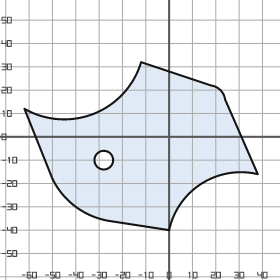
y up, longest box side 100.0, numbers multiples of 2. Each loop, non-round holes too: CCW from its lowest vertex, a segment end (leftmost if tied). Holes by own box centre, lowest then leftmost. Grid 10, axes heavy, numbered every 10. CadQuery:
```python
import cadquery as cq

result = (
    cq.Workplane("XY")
    .moveTo(0.0, -40.0)
    .threePointArc((14.0, -20.0), (38.0, -16.0))
    .lineTo(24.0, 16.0)
    .threePointArc((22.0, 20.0), (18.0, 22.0))
    .lineTo(-12.0, 32.0)
    .threePointArc((-32.0, 10.0), (-62.0, 12.0))
    .lineTo(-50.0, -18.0)
    .threePointArc((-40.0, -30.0), (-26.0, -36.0))
    .close()
    .moveTo(-28.0, -10.0)
    .circle(4.0)
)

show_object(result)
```